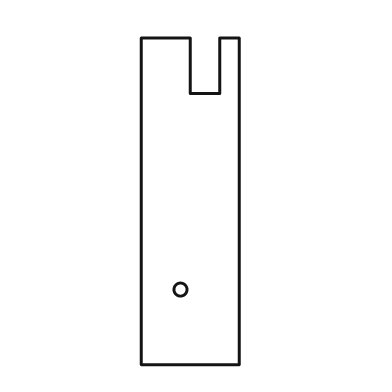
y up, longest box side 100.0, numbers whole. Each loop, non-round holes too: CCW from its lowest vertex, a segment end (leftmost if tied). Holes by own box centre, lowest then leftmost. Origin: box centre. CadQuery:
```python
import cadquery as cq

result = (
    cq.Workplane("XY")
    .moveTo(-15.0, -50.0)
    .lineTo(15.0, -50.0)
    .lineTo(15.0, 50.0)
    .lineTo(9.0, 50.0)
    .lineTo(9.0, 33.0)
    .lineTo(0.0, 33.0)
    .lineTo(0.0, 50.0)
    .lineTo(-15.0, 50.0)
    .close()
    .moveTo(-3.0, -27.0)
    .circle(2.0)
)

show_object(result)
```